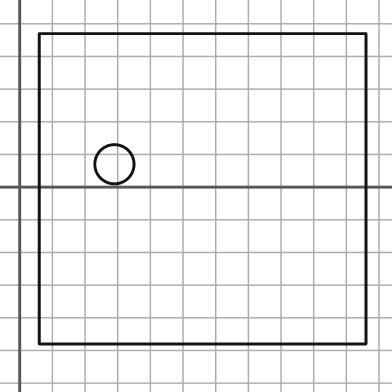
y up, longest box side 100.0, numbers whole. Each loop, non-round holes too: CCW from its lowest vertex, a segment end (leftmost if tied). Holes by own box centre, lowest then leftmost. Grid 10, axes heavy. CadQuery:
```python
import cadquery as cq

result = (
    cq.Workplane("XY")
    .moveTo(6.0, -48.0)
    .lineTo(106.0, -48.0)
    .lineTo(106.0, 47.0)
    .lineTo(6.0, 47.0)
    .close()
    .moveTo(29.0, 7.0)
    .circle(6.0)
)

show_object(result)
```